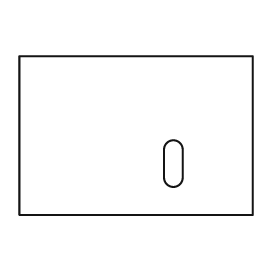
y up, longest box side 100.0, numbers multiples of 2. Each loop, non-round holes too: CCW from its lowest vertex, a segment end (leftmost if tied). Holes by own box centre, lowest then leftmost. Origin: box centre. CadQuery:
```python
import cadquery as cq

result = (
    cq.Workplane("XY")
    .moveTo(-50.0, -34.0)
    .lineTo(50.0, -34.0)
    .lineTo(50.0, 34.0)
    .lineTo(-50.0, 34.0)
    .close()
    .moveTo(12.0, -18.0)
    .threePointArc((16.0, -22.0), (20.0, -18.0))
    .lineTo(20.0, -6.0)
    .threePointArc((16.0, -2.0), (12.0, -6.0))
    .close()
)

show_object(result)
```